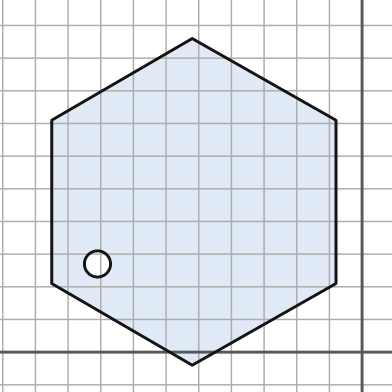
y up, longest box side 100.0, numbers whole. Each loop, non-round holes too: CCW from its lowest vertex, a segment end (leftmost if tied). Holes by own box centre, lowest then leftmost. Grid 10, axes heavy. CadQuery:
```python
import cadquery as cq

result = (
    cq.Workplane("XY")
    .moveTo(-52.0, -4.0)
    .lineTo(-8.0, 21.0)
    .lineTo(-8.0, 71.0)
    .lineTo(-52.0, 96.0)
    .lineTo(-95.0, 71.0)
    .lineTo(-95.0, 21.0)
    .close()
    .moveTo(-81.0, 27.0)
    .circle(4.0)
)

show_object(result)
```